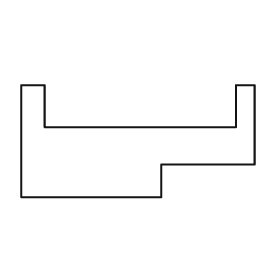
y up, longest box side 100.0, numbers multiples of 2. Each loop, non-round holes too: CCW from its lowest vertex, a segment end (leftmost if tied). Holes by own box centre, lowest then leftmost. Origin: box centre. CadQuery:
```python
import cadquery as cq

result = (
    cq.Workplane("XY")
    .moveTo(-50.0, -24.0)
    .lineTo(10.0, -24.0)
    .lineTo(10.0, -10.0)
    .lineTo(50.0, -10.0)
    .lineTo(50.0, 24.0)
    .lineTo(42.0, 24.0)
    .lineTo(42.0, 6.0)
    .lineTo(-40.0, 6.0)
    .lineTo(-40.0, 24.0)
    .lineTo(-50.0, 24.0)
    .close()
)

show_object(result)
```